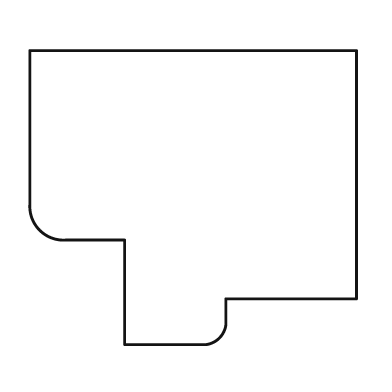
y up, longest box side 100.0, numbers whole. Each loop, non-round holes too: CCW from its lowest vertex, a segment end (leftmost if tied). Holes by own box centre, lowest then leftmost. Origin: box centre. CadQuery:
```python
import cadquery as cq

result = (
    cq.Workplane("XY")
    .moveTo(-21.0, -45.0)
    .lineTo(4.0, -45.0)
    .threePointArc((8.0, -43.0), (10.0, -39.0))
    .lineTo(10.0, -31.0)
    .lineTo(50.0, -31.0)
    .lineTo(50.0, 45.0)
    .lineTo(-50.0, 45.0)
    .lineTo(-50.0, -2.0)
    .threePointArc((-47.0, -10.0), (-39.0, -13.0))
    .lineTo(-21.0, -13.0)
    .close()
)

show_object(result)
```